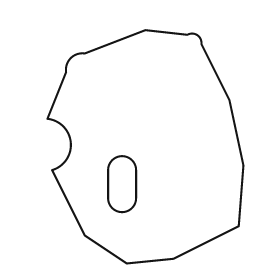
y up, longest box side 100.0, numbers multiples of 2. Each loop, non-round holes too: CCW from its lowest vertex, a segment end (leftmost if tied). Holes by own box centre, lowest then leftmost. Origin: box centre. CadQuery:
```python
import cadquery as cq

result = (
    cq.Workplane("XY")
    .moveTo(-8.0, -50.0)
    .lineTo(12.0, -48.0)
    .lineTo(40.0, -34.0)
    .lineTo(42.0, -8.0)
    .lineTo(36.0, 20.0)
    .lineTo(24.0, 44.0)
    .threePointArc((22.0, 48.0), (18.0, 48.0))
    .lineTo(0.0, 50.0)
    .lineTo(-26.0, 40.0)
    .threePointArc((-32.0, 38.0), (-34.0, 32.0))
    .lineTo(-42.0, 12.0)
    .threePointArc((-32.0, 2.0), (-40.0, -10.0))
    .lineTo(-26.0, -38.0)
    .close()
    .moveTo(-16.0, -22.0)
    .threePointArc((-10.0, -28.0), (-4.0, -22.0))
    .lineTo(-4.0, -10.0)
    .threePointArc((-10.0, -4.0), (-16.0, -10.0))
    .close()
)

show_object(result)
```